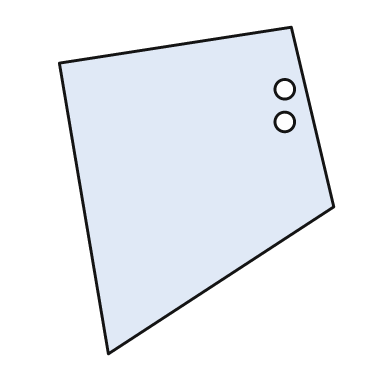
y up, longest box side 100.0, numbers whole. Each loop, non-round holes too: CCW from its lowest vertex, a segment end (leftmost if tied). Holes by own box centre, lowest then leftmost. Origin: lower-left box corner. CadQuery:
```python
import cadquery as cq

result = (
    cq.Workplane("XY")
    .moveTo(15.0, 0.0)
    .lineTo(84.0, 45.0)
    .lineTo(71.0, 100.0)
    .lineTo(0.0, 89.0)
    .close()
    .moveTo(69.0, 71.0)
    .circle(3.0)
    .moveTo(69.0, 81.0)
    .circle(3.0)
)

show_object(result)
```